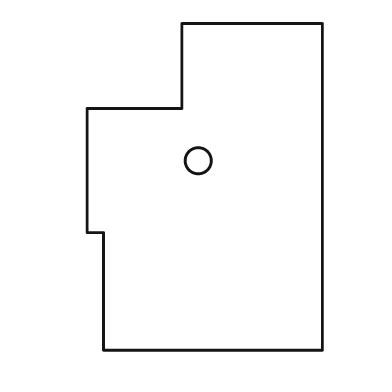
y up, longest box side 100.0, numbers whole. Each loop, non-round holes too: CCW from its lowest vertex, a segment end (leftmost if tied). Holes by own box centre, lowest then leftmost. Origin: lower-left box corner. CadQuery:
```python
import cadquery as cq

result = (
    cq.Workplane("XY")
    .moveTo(5.0, 0.0)
    .lineTo(72.0, 0.0)
    .lineTo(72.0, 100.0)
    .lineTo(29.0, 100.0)
    .lineTo(29.0, 74.0)
    .lineTo(0.0, 74.0)
    .lineTo(0.0, 36.0)
    .lineTo(5.0, 36.0)
    .close()
    .moveTo(34.0, 58.0)
    .circle(4.0)
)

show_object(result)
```